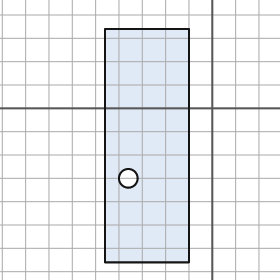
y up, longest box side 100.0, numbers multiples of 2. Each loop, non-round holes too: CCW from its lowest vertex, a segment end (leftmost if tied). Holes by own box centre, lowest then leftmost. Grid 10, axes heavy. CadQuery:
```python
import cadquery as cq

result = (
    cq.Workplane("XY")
    .moveTo(-46.0, -66.0)
    .lineTo(-10.0, -66.0)
    .lineTo(-10.0, 34.0)
    .lineTo(-46.0, 34.0)
    .close()
    .moveTo(-36.0, -30.0)
    .circle(4.0)
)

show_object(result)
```